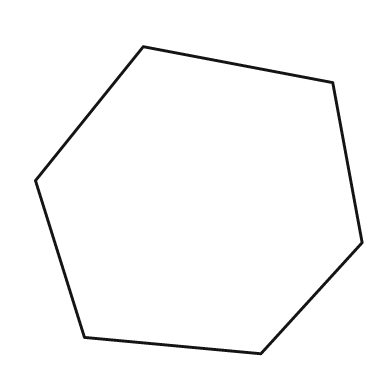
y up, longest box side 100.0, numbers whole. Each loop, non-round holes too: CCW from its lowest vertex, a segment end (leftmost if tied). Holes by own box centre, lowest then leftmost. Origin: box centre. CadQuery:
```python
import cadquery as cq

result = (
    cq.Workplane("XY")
    .moveTo(19.0, -47.0)
    .lineTo(50.0, -13.0)
    .lineTo(41.0, 36.0)
    .lineTo(-17.0, 47.0)
    .lineTo(-50.0, 6.0)
    .lineTo(-35.0, -42.0)
    .close()
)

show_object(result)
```